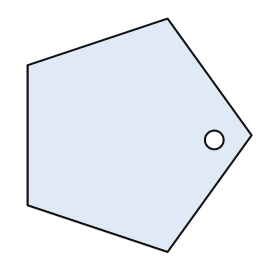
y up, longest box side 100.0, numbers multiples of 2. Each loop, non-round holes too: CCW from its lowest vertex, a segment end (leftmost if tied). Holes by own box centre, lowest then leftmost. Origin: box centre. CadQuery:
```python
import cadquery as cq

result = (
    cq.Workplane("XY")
    .moveTo(12.0, -50.0)
    .lineTo(48.0, 0.0)
    .lineTo(12.0, 50.0)
    .lineTo(-48.0, 30.0)
    .lineTo(-48.0, -30.0)
    .close()
    .moveTo(32.0, -2.0)
    .circle(4.0)
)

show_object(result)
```